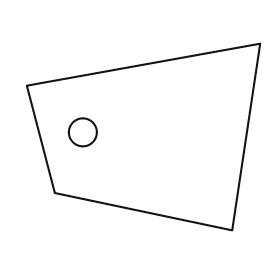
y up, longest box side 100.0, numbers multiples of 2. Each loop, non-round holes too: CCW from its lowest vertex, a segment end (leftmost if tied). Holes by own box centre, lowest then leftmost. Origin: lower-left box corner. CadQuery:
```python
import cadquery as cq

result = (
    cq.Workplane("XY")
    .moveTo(88.0, 0.0)
    .lineTo(100.0, 80.0)
    .lineTo(0.0, 62.0)
    .lineTo(12.0, 16.0)
    .close()
    .moveTo(24.0, 42.0)
    .circle(6.0)
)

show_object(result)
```